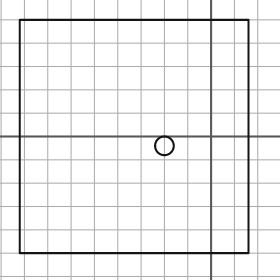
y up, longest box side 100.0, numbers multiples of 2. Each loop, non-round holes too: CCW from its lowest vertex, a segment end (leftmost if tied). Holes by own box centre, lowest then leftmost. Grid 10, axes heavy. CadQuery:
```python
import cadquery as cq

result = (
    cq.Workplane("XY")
    .moveTo(-82.0, -50.0)
    .lineTo(16.0, -50.0)
    .lineTo(16.0, 50.0)
    .lineTo(-82.0, 50.0)
    .close()
    .moveTo(-20.0, -4.0)
    .circle(4.0)
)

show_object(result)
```